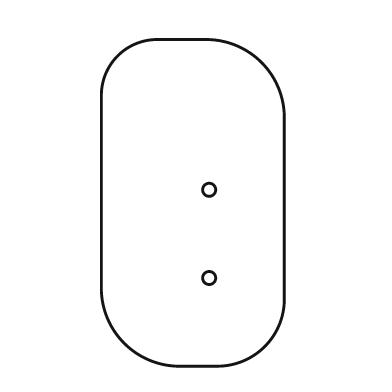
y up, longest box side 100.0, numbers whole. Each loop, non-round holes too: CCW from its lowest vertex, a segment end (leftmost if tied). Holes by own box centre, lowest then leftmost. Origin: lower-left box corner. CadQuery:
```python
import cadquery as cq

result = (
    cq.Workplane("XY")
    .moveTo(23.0, 0.0)
    .lineTo(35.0, 0.0)
    .threePointArc((50.0, 6.0), (56.0, 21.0))
    .lineTo(56.0, 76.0)
    .threePointArc((49.0, 93.0), (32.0, 100.0))
    .lineTo(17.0, 100.0)
    .threePointArc((5.0, 95.0), (0.0, 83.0))
    .lineTo(0.0, 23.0)
    .threePointArc((7.0, 7.0), (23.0, 0.0))
    .close()
    .moveTo(33.0, 27.0)
    .circle(2.0)
    .moveTo(33.0, 54.0)
    .circle(2.0)
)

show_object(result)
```